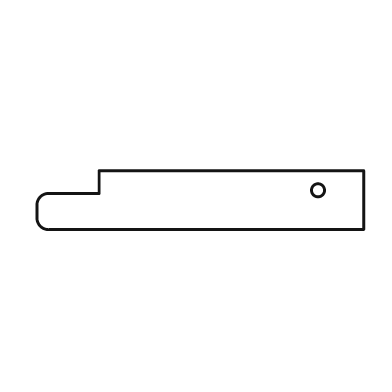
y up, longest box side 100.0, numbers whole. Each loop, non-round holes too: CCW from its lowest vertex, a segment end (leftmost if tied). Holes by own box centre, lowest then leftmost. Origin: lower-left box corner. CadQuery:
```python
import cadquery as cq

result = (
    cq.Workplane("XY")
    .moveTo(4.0, 0.0)
    .lineTo(100.0, 0.0)
    .lineTo(100.0, 18.0)
    .lineTo(19.0, 18.0)
    .lineTo(19.0, 11.0)
    .lineTo(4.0, 11.0)
    .threePointArc((1.0, 10.0), (0.0, 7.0))
    .lineTo(0.0, 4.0)
    .threePointArc((1.0, 1.0), (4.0, 0.0))
    .close()
    .moveTo(86.0, 12.0)
    .circle(2.0)
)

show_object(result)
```